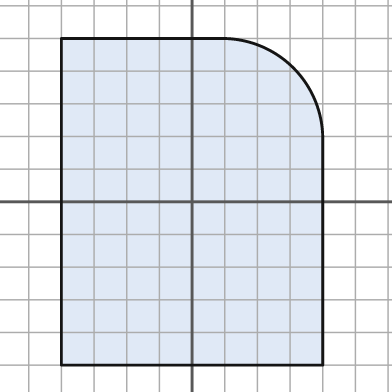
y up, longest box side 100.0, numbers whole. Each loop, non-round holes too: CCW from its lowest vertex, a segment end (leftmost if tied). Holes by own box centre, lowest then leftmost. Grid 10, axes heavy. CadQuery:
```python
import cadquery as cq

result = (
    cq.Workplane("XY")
    .moveTo(-40.0, -50.0)
    .lineTo(40.0, -50.0)
    .lineTo(40.0, 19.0)
    .threePointArc((31.0, 41.0), (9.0, 50.0))
    .lineTo(-40.0, 50.0)
    .close()
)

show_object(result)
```